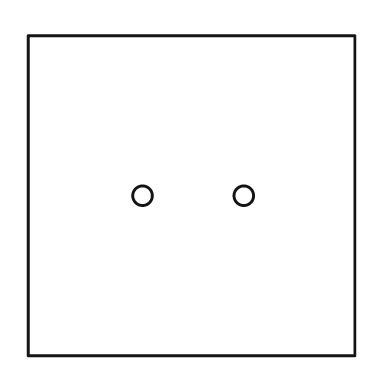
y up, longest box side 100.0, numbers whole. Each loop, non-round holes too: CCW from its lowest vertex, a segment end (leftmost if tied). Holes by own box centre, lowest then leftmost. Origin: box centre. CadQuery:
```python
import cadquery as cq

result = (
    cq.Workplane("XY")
    .moveTo(-50.0, -49.0)
    .lineTo(50.0, -49.0)
    .lineTo(50.0, 49.0)
    .lineTo(-50.0, 49.0)
    .close()
    .moveTo(-15.0, 0.0)
    .circle(3.0)
    .moveTo(16.0, 0.0)
    .circle(3.0)
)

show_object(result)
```